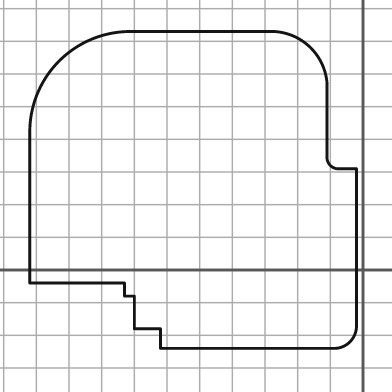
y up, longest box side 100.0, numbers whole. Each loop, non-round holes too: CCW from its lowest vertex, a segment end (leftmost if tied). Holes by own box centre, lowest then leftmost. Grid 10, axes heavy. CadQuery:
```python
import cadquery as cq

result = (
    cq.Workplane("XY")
    .moveTo(-62.0, -24.0)
    .lineTo(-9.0, -24.0)
    .threePointArc((-4.0, -22.0), (-2.0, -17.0))
    .lineTo(-2.0, 31.0)
    .lineTo(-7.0, 31.0)
    .threePointArc((-10.0, 32.0), (-11.0, 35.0))
    .lineTo(-11.0, 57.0)
    .threePointArc((-16.0, 68.0), (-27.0, 73.0))
    .lineTo(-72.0, 73.0)
    .threePointArc((-93.0, 64.0), (-102.0, 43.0))
    .lineTo(-102.0, -4.0)
    .lineTo(-73.0, -4.0)
    .lineTo(-73.0, -8.0)
    .lineTo(-70.0, -8.0)
    .lineTo(-70.0, -18.0)
    .lineTo(-62.0, -18.0)
    .close()
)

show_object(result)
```